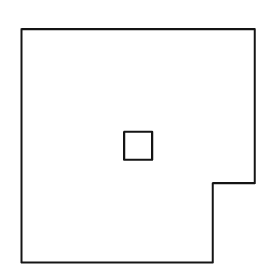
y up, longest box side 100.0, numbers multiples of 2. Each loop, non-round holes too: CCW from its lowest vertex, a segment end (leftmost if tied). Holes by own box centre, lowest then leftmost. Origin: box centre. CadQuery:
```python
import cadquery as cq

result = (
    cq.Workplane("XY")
    .moveTo(-50.0, -50.0)
    .lineTo(32.0, -50.0)
    .lineTo(32.0, -16.0)
    .lineTo(50.0, -16.0)
    .lineTo(50.0, 50.0)
    .lineTo(-50.0, 50.0)
    .close()
    .moveTo(-6.0, -6.0)
    .lineTo(6.0, -6.0)
    .lineTo(6.0, 6.0)
    .lineTo(-6.0, 6.0)
    .close()
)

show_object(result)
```